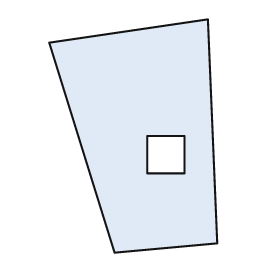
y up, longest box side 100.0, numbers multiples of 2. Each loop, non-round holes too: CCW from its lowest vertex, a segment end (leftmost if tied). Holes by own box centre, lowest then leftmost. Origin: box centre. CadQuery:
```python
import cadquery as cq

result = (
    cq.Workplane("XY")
    .moveTo(-8.0, -50.0)
    .lineTo(36.0, -46.0)
    .lineTo(32.0, 50.0)
    .lineTo(-36.0, 40.0)
    .close()
    .moveTo(6.0, -16.0)
    .lineTo(22.0, -16.0)
    .lineTo(22.0, 0.0)
    .lineTo(6.0, 0.0)
    .close()
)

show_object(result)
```